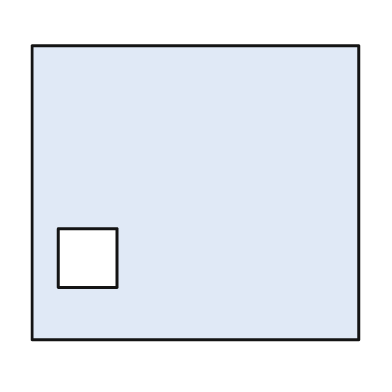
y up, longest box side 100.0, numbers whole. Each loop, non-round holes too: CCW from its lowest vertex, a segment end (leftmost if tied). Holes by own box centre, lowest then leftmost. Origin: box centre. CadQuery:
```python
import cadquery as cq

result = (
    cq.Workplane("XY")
    .moveTo(-50.0, -45.0)
    .lineTo(50.0, -45.0)
    .lineTo(50.0, 45.0)
    .lineTo(-50.0, 45.0)
    .close()
    .moveTo(-42.0, -29.0)
    .lineTo(-24.0, -29.0)
    .lineTo(-24.0, -11.0)
    .lineTo(-42.0, -11.0)
    .close()
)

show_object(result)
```